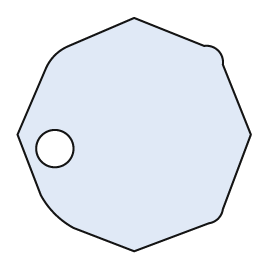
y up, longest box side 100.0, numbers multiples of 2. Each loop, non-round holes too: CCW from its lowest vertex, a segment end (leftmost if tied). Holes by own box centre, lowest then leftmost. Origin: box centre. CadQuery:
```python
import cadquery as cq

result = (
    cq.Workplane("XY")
    .moveTo(0.0, -50.0)
    .lineTo(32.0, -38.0)
    .threePointArc((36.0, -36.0), (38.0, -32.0))
    .lineTo(50.0, 0.0)
    .lineTo(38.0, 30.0)
    .threePointArc((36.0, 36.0), (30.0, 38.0))
    .lineTo(0.0, 50.0)
    .lineTo(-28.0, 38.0)
    .threePointArc((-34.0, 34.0), (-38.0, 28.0))
    .lineTo(-50.0, 0.0)
    .lineTo(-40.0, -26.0)
    .threePointArc((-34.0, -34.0), (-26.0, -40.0))
    .close()
    .moveTo(-34.0, -6.0)
    .circle(8.0)
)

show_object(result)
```